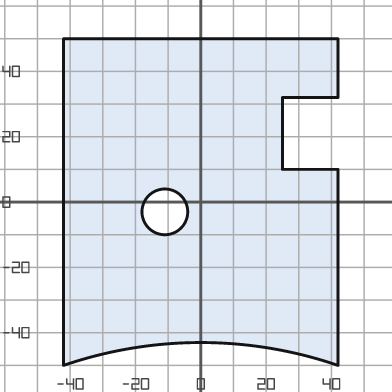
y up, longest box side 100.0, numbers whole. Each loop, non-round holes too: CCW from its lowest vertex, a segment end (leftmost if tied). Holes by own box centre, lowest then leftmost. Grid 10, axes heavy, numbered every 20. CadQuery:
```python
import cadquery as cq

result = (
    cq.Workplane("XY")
    .moveTo(-42.0, -50.0)
    .threePointArc((0.0, -43.0), (42.0, -50.0))
    .lineTo(42.0, 10.0)
    .lineTo(25.0, 10.0)
    .lineTo(25.0, 32.0)
    .lineTo(42.0, 32.0)
    .lineTo(42.0, 50.0)
    .lineTo(-42.0, 50.0)
    .close()
    .moveTo(-11.0, -3.0)
    .circle(7.0)
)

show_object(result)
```